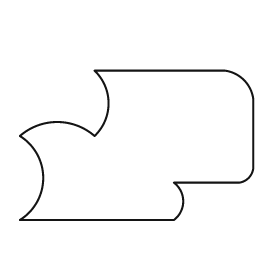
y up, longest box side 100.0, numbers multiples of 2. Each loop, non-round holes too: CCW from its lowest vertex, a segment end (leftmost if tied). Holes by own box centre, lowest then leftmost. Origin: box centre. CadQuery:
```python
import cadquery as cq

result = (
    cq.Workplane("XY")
    .moveTo(-50.0, -32.0)
    .lineTo(16.0, -32.0)
    .threePointArc((20.0, -24.0), (16.0, -16.0))
    .lineTo(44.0, -16.0)
    .threePointArc((48.0, -14.0), (50.0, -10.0))
    .lineTo(50.0, 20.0)
    .threePointArc((46.0, 28.0), (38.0, 32.0))
    .lineTo(-18.0, 32.0)
    .threePointArc((-12.0, 18.0), (-18.0, 4.0))
    .threePointArc((-34.0, 10.0), (-50.0, 4.0))
    .threePointArc((-40.0, -14.0), (-50.0, -32.0))
    .close()
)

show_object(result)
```